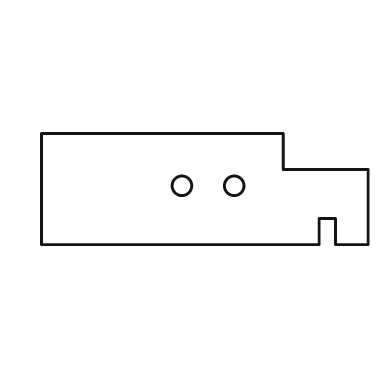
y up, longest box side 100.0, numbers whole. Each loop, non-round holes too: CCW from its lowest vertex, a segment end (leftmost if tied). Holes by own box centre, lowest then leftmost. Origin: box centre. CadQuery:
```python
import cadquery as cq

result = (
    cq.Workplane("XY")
    .moveTo(-50.0, -17.0)
    .lineTo(35.0, -17.0)
    .lineTo(35.0, -9.0)
    .lineTo(40.0, -9.0)
    .lineTo(40.0, -17.0)
    .lineTo(50.0, -17.0)
    .lineTo(50.0, 6.0)
    .lineTo(24.0, 6.0)
    .lineTo(24.0, 17.0)
    .lineTo(-50.0, 17.0)
    .close()
    .moveTo(-7.0, 1.0)
    .circle(3.0)
    .moveTo(9.0, 1.0)
    .circle(3.0)
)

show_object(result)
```